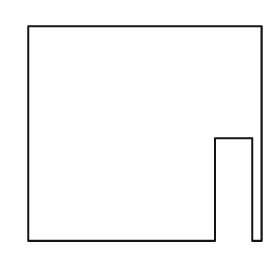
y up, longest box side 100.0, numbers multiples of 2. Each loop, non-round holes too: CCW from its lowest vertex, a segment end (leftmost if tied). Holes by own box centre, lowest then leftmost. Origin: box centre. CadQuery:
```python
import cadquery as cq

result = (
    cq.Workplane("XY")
    .moveTo(-50.0, -46.0)
    .lineTo(30.0, -46.0)
    .lineTo(30.0, -2.0)
    .lineTo(46.0, -2.0)
    .lineTo(46.0, -46.0)
    .lineTo(50.0, -46.0)
    .lineTo(50.0, 46.0)
    .lineTo(-50.0, 46.0)
    .close()
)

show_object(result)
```